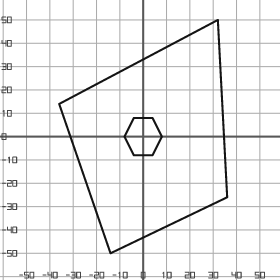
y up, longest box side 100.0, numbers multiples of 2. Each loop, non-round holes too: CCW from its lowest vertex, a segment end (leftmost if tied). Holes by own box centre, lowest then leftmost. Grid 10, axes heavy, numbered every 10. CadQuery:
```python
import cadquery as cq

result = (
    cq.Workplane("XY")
    .moveTo(-14.0, -50.0)
    .lineTo(36.0, -26.0)
    .lineTo(32.0, 50.0)
    .lineTo(-36.0, 14.0)
    .close()
    .moveTo(-4.0, -8.0)
    .lineTo(4.0, -8.0)
    .lineTo(8.0, 0.0)
    .lineTo(4.0, 8.0)
    .lineTo(-4.0, 8.0)
    .lineTo(-8.0, 0.0)
    .close()
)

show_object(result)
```